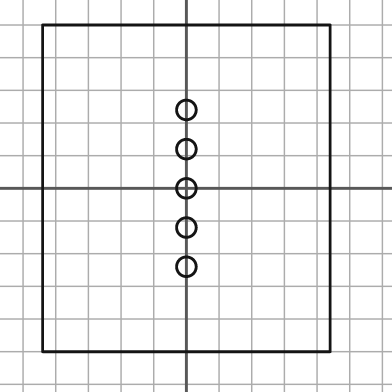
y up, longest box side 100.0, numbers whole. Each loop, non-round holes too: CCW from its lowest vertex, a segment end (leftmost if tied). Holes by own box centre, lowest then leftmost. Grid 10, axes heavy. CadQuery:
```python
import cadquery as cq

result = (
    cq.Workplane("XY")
    .moveTo(-44.0, -50.0)
    .lineTo(44.0, -50.0)
    .lineTo(44.0, 50.0)
    .lineTo(-44.0, 50.0)
    .close()
    .moveTo(0.0, -24.0)
    .circle(3.0)
    .moveTo(0.0, -12.0)
    .circle(3.0)
    .moveTo(0.0, 0.0)
    .circle(3.0)
    .moveTo(0.0, 12.0)
    .circle(3.0)
    .moveTo(0.0, 24.0)
    .circle(3.0)
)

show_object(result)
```